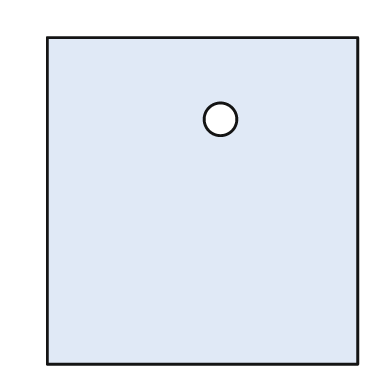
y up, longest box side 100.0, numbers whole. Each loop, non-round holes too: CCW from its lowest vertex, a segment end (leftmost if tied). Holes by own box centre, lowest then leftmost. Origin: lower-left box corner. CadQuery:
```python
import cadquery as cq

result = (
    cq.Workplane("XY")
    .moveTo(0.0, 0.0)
    .lineTo(95.0, 0.0)
    .lineTo(95.0, 100.0)
    .lineTo(0.0, 100.0)
    .close()
    .moveTo(53.0, 75.0)
    .circle(5.0)
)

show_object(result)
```